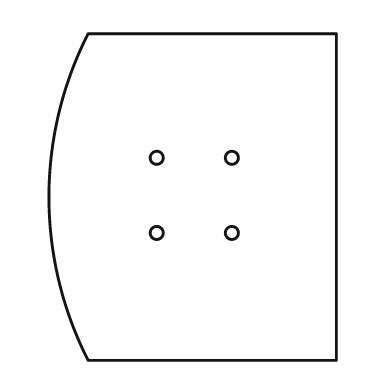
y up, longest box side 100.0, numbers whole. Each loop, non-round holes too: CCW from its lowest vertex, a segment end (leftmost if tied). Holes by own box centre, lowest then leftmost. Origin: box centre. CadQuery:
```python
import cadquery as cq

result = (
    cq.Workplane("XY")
    .moveTo(-32.0, -50.0)
    .lineTo(44.0, -50.0)
    .lineTo(44.0, 50.0)
    .lineTo(-32.0, 50.0)
    .threePointArc((-44.0, 0.0), (-32.0, -50.0))
    .close()
    .moveTo(-11.0, -11.0)
    .circle(2.0)
    .moveTo(12.0, -11.0)
    .circle(2.0)
    .moveTo(-11.0, 12.0)
    .circle(2.0)
    .moveTo(12.0, 12.0)
    .circle(2.0)
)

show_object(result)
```